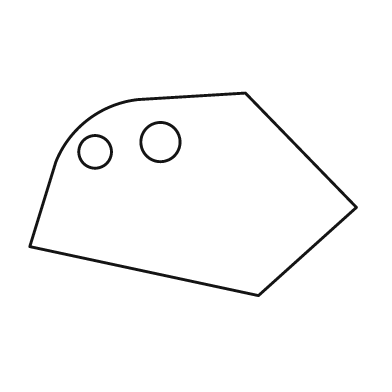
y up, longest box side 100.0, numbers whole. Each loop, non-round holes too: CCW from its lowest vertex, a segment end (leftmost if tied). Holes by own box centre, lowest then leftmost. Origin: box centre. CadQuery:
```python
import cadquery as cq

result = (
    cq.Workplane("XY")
    .moveTo(20.0, -31.0)
    .lineTo(50.0, -4.0)
    .lineTo(16.0, 31.0)
    .lineTo(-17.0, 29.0)
    .threePointArc((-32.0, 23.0), (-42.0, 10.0))
    .lineTo(-50.0, -16.0)
    .close()
    .moveTo(-30.0, 13.0)
    .circle(5.0)
    .moveTo(-10.0, 16.0)
    .circle(6.0)
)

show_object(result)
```